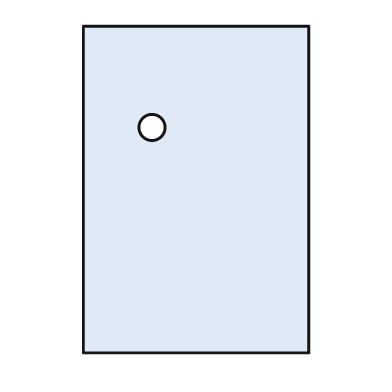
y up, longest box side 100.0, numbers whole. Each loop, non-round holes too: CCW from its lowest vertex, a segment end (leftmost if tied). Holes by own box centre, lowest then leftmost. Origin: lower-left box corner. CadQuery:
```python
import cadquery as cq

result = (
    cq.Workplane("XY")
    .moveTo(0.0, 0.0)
    .lineTo(69.0, 0.0)
    .lineTo(69.0, 100.0)
    .lineTo(0.0, 100.0)
    .close()
    .moveTo(21.0, 69.0)
    .circle(4.0)
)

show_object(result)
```